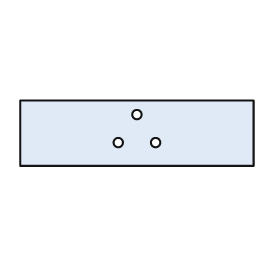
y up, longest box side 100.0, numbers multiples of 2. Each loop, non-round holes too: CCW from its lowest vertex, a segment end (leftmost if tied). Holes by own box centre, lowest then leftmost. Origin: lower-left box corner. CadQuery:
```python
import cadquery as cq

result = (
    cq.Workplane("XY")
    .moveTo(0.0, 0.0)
    .lineTo(100.0, 0.0)
    .lineTo(100.0, 28.0)
    .lineTo(0.0, 28.0)
    .close()
    .moveTo(42.0, 10.0)
    .circle(2.0)
    .moveTo(58.0, 10.0)
    .circle(2.0)
    .moveTo(50.0, 22.0)
    .circle(2.0)
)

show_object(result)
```